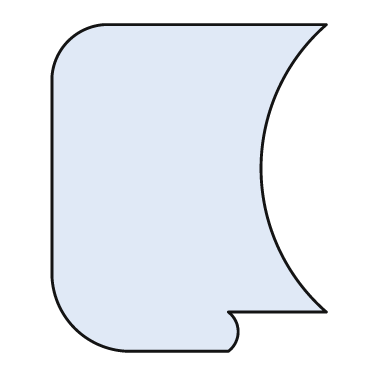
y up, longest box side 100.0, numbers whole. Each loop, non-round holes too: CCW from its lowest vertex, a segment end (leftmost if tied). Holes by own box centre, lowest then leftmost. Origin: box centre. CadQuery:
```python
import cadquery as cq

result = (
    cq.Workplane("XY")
    .moveTo(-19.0, -50.0)
    .lineTo(12.0, -50.0)
    .threePointArc((15.0, -44.0), (12.0, -38.0))
    .lineTo(42.0, -38.0)
    .threePointArc((22.0, 6.0), (42.0, 50.0))
    .lineTo(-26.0, 50.0)
    .threePointArc((-37.0, 45.0), (-42.0, 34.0))
    .lineTo(-42.0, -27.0)
    .threePointArc((-35.0, -43.0), (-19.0, -50.0))
    .close()
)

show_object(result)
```